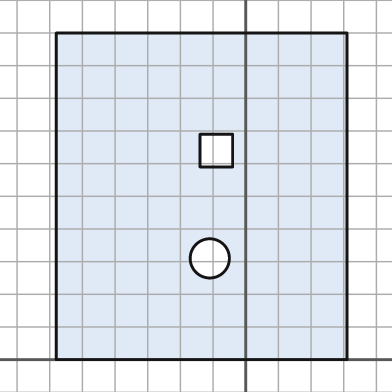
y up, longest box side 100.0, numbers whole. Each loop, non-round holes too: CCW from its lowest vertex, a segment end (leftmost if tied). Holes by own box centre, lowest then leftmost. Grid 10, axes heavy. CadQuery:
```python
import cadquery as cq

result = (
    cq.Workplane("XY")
    .moveTo(-58.0, 0.0)
    .lineTo(31.0, 0.0)
    .lineTo(31.0, 100.0)
    .lineTo(-58.0, 100.0)
    .close()
    .moveTo(-11.0, 31.0)
    .circle(6.0)
    .moveTo(-14.0, 59.0)
    .lineTo(-4.0, 59.0)
    .lineTo(-4.0, 69.0)
    .lineTo(-14.0, 69.0)
    .close()
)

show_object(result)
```